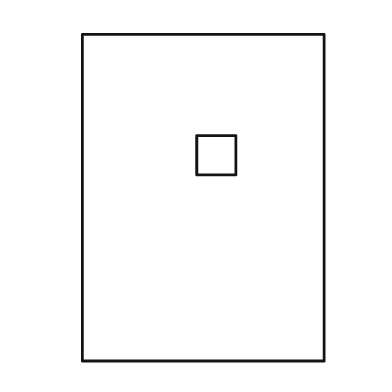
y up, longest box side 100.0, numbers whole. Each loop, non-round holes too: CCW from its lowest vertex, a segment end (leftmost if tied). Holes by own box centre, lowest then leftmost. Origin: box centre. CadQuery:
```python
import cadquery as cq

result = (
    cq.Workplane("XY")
    .moveTo(-37.0, -50.0)
    .lineTo(37.0, -50.0)
    .lineTo(37.0, 50.0)
    .lineTo(-37.0, 50.0)
    .close()
    .moveTo(-2.0, 7.0)
    .lineTo(10.0, 7.0)
    .lineTo(10.0, 19.0)
    .lineTo(-2.0, 19.0)
    .close()
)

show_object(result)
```